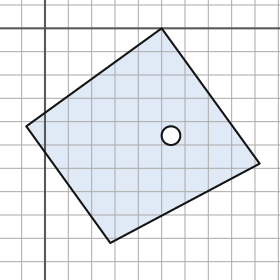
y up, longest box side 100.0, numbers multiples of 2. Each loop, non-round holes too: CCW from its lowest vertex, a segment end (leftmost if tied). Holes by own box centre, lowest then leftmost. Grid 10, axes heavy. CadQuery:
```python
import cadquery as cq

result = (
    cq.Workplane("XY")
    .moveTo(28.0, -92.0)
    .lineTo(92.0, -58.0)
    .lineTo(50.0, 0.0)
    .lineTo(-8.0, -42.0)
    .close()
    .moveTo(54.0, -46.0)
    .circle(4.0)
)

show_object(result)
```